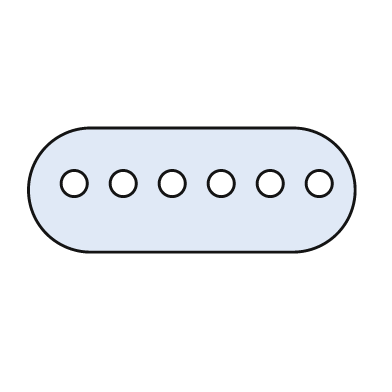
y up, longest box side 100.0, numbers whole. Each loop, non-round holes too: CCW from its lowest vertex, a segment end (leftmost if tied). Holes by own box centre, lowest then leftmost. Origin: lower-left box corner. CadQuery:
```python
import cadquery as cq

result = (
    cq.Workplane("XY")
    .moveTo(19.0, 0.0)
    .lineTo(81.0, 0.0)
    .threePointArc((100.0, 19.0), (81.0, 38.0))
    .lineTo(19.0, 38.0)
    .threePointArc((0.0, 19.0), (19.0, 0.0))
    .close()
    .moveTo(14.0, 21.0)
    .circle(4.0)
    .moveTo(29.0, 21.0)
    .circle(4.0)
    .moveTo(44.0, 21.0)
    .circle(4.0)
    .moveTo(59.0, 21.0)
    .circle(4.0)
    .moveTo(74.0, 21.0)
    .circle(4.0)
    .moveTo(89.0, 21.0)
    .circle(4.0)
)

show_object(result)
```